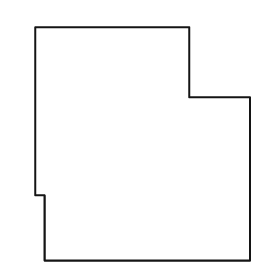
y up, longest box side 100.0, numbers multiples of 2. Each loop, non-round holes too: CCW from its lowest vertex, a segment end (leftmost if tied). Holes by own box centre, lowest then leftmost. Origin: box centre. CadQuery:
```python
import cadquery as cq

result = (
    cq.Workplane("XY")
    .moveTo(-42.0, -50.0)
    .lineTo(46.0, -50.0)
    .lineTo(46.0, 20.0)
    .lineTo(20.0, 20.0)
    .lineTo(20.0, 50.0)
    .lineTo(-46.0, 50.0)
    .lineTo(-46.0, -22.0)
    .lineTo(-42.0, -22.0)
    .close()
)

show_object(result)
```